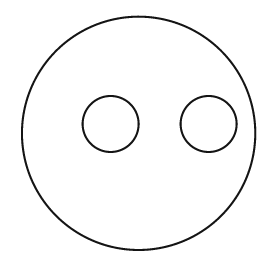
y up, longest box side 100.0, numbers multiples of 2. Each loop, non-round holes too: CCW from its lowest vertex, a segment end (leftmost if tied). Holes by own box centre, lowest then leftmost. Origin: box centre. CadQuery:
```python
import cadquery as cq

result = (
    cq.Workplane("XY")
    .moveTo(0.0, 0.0)
    .circle(50.0)
    .moveTo(-12.0, 4.0)
    .circle(12.0)
    .moveTo(30.0, 4.0)
    .circle(12.0)
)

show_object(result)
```